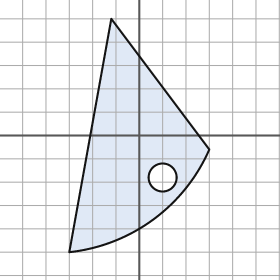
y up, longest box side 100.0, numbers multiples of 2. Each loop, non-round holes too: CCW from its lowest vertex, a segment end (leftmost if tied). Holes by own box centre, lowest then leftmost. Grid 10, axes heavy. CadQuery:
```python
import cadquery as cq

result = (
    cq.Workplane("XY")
    .moveTo(-30.0, -50.0)
    .threePointArc((6.0, -36.0), (30.0, -6.0))
    .lineTo(-12.0, 50.0)
    .close()
    .moveTo(10.0, -18.0)
    .circle(6.0)
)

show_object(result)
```